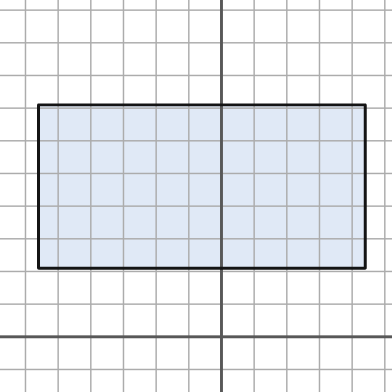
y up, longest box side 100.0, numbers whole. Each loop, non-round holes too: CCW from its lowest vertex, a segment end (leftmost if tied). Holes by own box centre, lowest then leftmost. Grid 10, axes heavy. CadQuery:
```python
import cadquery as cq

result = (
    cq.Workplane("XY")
    .moveTo(-56.0, 21.0)
    .lineTo(44.0, 21.0)
    .lineTo(44.0, 71.0)
    .lineTo(-56.0, 71.0)
    .close()
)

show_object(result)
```